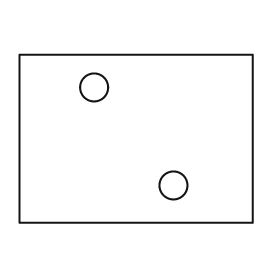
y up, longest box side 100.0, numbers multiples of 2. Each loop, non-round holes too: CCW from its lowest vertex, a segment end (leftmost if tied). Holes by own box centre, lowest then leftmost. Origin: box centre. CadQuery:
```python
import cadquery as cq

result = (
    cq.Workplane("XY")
    .moveTo(-50.0, -36.0)
    .lineTo(50.0, -36.0)
    .lineTo(50.0, 36.0)
    .lineTo(-50.0, 36.0)
    .close()
    .moveTo(16.0, -20.0)
    .circle(6.0)
    .moveTo(-18.0, 22.0)
    .circle(6.0)
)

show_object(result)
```